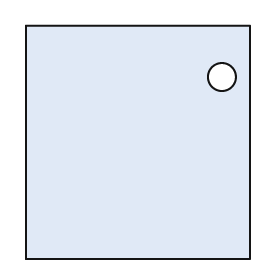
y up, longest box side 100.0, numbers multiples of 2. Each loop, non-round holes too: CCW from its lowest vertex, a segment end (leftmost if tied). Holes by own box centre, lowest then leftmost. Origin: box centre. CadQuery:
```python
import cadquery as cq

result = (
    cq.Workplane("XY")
    .moveTo(-48.0, -50.0)
    .lineTo(48.0, -50.0)
    .lineTo(48.0, 50.0)
    .lineTo(-48.0, 50.0)
    .close()
    .moveTo(36.0, 28.0)
    .circle(6.0)
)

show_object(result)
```